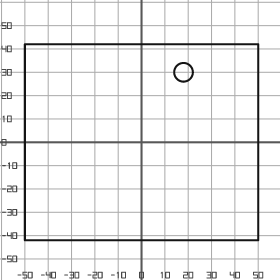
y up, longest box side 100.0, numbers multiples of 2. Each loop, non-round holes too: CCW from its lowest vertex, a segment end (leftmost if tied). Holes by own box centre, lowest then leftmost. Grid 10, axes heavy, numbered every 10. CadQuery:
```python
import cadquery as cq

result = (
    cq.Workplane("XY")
    .moveTo(-50.0, -42.0)
    .lineTo(50.0, -42.0)
    .lineTo(50.0, 42.0)
    .lineTo(-50.0, 42.0)
    .close()
    .moveTo(18.0, 30.0)
    .circle(4.0)
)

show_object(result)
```